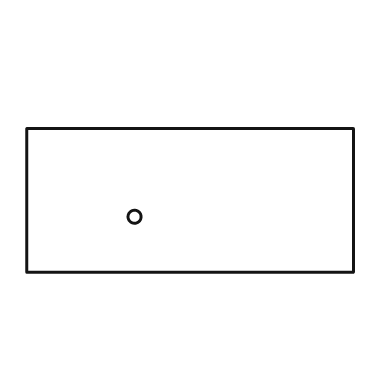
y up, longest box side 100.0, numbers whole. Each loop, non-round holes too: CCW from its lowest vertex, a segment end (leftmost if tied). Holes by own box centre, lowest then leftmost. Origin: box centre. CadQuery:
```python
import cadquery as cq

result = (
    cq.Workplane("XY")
    .moveTo(-50.0, -22.0)
    .lineTo(50.0, -22.0)
    .lineTo(50.0, 22.0)
    .lineTo(-50.0, 22.0)
    .close()
    .moveTo(-17.0, -5.0)
    .circle(2.0)
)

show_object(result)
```